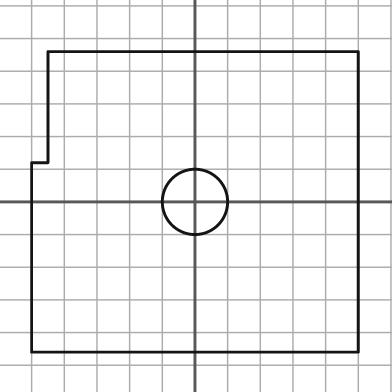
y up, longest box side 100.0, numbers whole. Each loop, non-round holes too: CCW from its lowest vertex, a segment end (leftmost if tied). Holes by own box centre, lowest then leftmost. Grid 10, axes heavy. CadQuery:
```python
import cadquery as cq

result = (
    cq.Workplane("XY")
    .moveTo(-50.0, -46.0)
    .lineTo(50.0, -46.0)
    .lineTo(50.0, 46.0)
    .lineTo(-45.0, 46.0)
    .lineTo(-45.0, 12.0)
    .lineTo(-50.0, 12.0)
    .close()
    .moveTo(0.0, 0.0)
    .circle(10.0)
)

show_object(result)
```